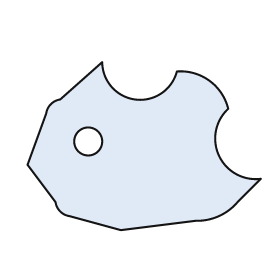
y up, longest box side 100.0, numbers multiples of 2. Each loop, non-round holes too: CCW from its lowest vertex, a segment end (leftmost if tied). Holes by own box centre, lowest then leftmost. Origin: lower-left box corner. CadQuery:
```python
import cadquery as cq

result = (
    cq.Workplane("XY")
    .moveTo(40.0, 0.0)
    .lineTo(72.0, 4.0)
    .threePointArc((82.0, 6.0), (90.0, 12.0))
    .lineTo(100.0, 22.0)
    .threePointArc((82.0, 32.0), (86.0, 52.0))
    .threePointArc((78.0, 64.0), (64.0, 68.0))
    .threePointArc((46.0, 56.0), (32.0, 72.0))
    .lineTo(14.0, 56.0)
    .threePointArc((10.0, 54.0), (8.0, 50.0))
    .lineTo(0.0, 28.0)
    .lineTo(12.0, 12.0)
    .threePointArc((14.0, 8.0), (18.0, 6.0))
    .close()
    .moveTo(26.0, 38.0)
    .circle(6.0)
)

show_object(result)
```